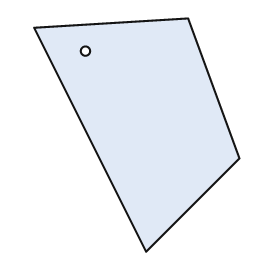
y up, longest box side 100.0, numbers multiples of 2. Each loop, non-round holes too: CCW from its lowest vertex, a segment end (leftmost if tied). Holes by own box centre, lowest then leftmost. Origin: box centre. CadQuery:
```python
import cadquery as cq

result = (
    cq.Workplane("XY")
    .moveTo(4.0, -50.0)
    .lineTo(44.0, -10.0)
    .lineTo(22.0, 50.0)
    .lineTo(-44.0, 46.0)
    .close()
    .moveTo(-22.0, 36.0)
    .circle(2.0)
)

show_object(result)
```